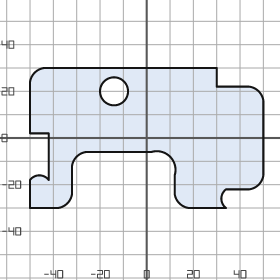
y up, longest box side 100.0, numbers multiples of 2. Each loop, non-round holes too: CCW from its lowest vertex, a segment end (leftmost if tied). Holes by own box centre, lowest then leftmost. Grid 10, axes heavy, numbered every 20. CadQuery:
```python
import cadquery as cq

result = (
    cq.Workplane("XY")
    .moveTo(-50.0, -30.0)
    .lineTo(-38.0, -30.0)
    .threePointArc((-34.0, -28.0), (-32.0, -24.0))
    .lineTo(-32.0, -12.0)
    .threePointArc((-30.0, -8.0), (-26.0, -6.0))
    .lineTo(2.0, -6.0)
    .threePointArc((10.0, -8.0), (12.0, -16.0))
    .lineTo(12.0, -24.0)
    .threePointArc((14.0, -28.0), (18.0, -30.0))
    .lineTo(34.0, -30.0)
    .threePointArc((32.0, -26.0), (34.0, -22.0))
    .lineTo(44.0, -22.0)
    .threePointArc((48.0, -20.0), (50.0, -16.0))
    .lineTo(50.0, 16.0)
    .threePointArc((48.0, 20.0), (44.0, 22.0))
    .lineTo(30.0, 22.0)
    .lineTo(30.0, 30.0)
    .lineTo(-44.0, 30.0)
    .threePointArc((-48.0, 28.0), (-50.0, 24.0))
    .lineTo(-50.0, 2.0)
    .lineTo(-42.0, 2.0)
    .lineTo(-42.0, -18.0)
    .threePointArc((-46.0, -16.0), (-50.0, -18.0))
    .close()
    .moveTo(-14.0, 20.0)
    .circle(6.0)
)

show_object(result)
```